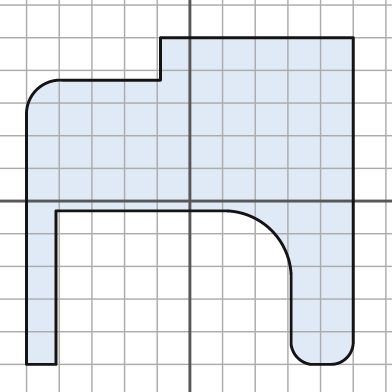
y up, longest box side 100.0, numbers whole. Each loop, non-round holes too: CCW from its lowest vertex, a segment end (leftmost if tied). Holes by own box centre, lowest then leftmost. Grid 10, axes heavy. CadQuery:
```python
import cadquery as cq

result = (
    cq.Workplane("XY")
    .moveTo(-50.0, -50.0)
    .lineTo(-41.0, -50.0)
    .lineTo(-41.0, -3.0)
    .lineTo(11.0, -3.0)
    .threePointArc((25.0, -9.0), (31.0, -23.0))
    .lineTo(31.0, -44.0)
    .threePointArc((33.0, -48.0), (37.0, -50.0))
    .lineTo(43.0, -50.0)
    .threePointArc((48.0, -48.0), (50.0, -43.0))
    .lineTo(50.0, 50.0)
    .lineTo(-9.0, 50.0)
    .lineTo(-9.0, 37.0)
    .lineTo(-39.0, 37.0)
    .threePointArc((-47.0, 34.0), (-50.0, 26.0))
    .close()
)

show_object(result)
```